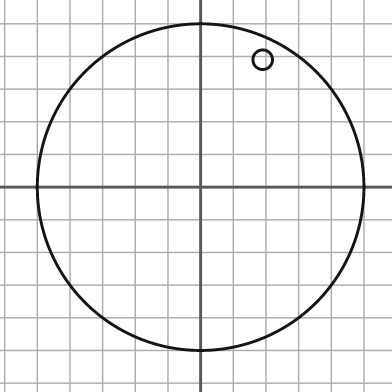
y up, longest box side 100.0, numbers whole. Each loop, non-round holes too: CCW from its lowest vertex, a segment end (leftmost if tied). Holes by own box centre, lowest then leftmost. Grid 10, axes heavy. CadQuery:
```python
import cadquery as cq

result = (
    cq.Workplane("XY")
    .moveTo(0.0, 0.0)
    .circle(50.0)
    .moveTo(19.0, 39.0)
    .circle(3.0)
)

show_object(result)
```